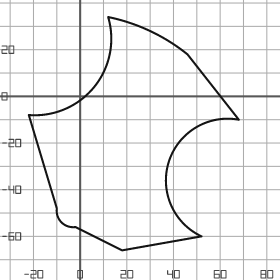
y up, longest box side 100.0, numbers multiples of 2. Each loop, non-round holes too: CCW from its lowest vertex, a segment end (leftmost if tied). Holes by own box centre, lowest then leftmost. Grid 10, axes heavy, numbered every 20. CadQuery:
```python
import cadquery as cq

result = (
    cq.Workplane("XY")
    .moveTo(18.0, -66.0)
    .lineTo(52.0, -60.0)
    .threePointArc((38.0, -28.0), (68.0, -10.0))
    .lineTo(46.0, 18.0)
    .threePointArc((30.0, 28.0), (12.0, 34.0))
    .threePointArc((6.0, 4.0), (-22.0, -8.0))
    .lineTo(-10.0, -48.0)
    .threePointArc((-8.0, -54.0), (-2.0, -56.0))
    .close()
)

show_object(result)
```